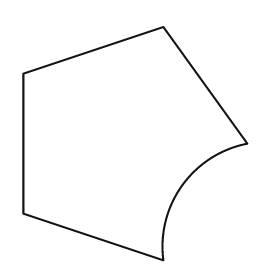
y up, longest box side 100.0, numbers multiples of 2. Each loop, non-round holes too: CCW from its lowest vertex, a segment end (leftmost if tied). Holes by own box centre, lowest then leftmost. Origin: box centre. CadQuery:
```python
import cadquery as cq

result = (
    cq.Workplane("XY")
    .moveTo(12.0, -50.0)
    .threePointArc((20.0, -18.0), (48.0, 0.0))
    .lineTo(12.0, 50.0)
    .lineTo(-48.0, 30.0)
    .lineTo(-48.0, -30.0)
    .close()
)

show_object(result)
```